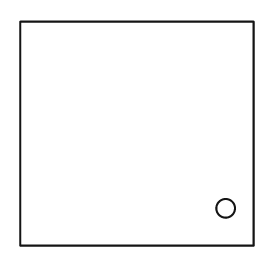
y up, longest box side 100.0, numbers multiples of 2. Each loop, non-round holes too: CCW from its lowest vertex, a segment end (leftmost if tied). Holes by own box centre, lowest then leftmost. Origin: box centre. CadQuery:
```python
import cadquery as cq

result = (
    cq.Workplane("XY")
    .moveTo(-50.0, -48.0)
    .lineTo(50.0, -48.0)
    .lineTo(50.0, 48.0)
    .lineTo(-50.0, 48.0)
    .close()
    .moveTo(38.0, -32.0)
    .circle(4.0)
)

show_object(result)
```